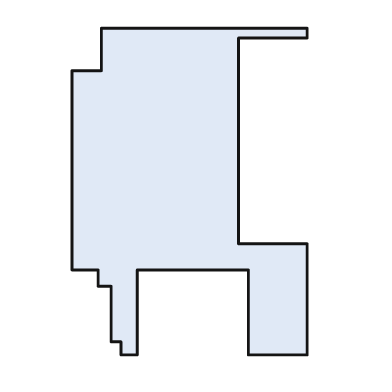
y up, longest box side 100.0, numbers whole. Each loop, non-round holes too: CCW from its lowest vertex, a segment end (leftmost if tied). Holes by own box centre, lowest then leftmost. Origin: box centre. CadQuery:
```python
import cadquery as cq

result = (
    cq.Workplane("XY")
    .moveTo(-21.0, -50.0)
    .lineTo(-16.0, -50.0)
    .lineTo(-16.0, -24.0)
    .lineTo(18.0, -24.0)
    .lineTo(18.0, -50.0)
    .lineTo(36.0, -50.0)
    .lineTo(36.0, -16.0)
    .lineTo(15.0, -16.0)
    .lineTo(15.0, 47.0)
    .lineTo(36.0, 47.0)
    .lineTo(36.0, 50.0)
    .lineTo(-27.0, 50.0)
    .lineTo(-27.0, 37.0)
    .lineTo(-36.0, 37.0)
    .lineTo(-36.0, -24.0)
    .lineTo(-28.0, -24.0)
    .lineTo(-28.0, -29.0)
    .lineTo(-24.0, -29.0)
    .lineTo(-24.0, -46.0)
    .lineTo(-21.0, -46.0)
    .close()
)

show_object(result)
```